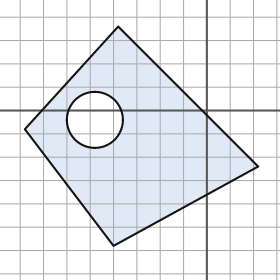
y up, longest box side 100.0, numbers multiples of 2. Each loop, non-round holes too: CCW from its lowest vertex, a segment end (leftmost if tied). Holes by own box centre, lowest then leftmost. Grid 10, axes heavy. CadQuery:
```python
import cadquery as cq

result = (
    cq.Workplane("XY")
    .moveTo(-40.0, -58.0)
    .lineTo(22.0, -24.0)
    .lineTo(-38.0, 36.0)
    .lineTo(-78.0, -8.0)
    .close()
    .moveTo(-48.0, -4.0)
    .circle(12.0)
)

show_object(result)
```